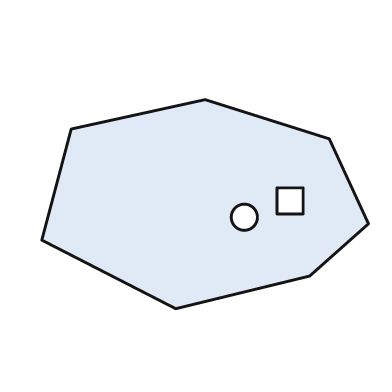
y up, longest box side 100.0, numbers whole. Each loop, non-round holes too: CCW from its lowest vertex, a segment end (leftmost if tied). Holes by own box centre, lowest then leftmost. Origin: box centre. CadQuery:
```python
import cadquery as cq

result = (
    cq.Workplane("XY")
    .moveTo(-9.0, -32.0)
    .lineTo(32.0, -22.0)
    .lineTo(50.0, -6.0)
    .lineTo(38.0, 20.0)
    .lineTo(0.0, 32.0)
    .lineTo(-41.0, 23.0)
    .lineTo(-50.0, -11.0)
    .close()
    .moveTo(12.0, -4.0)
    .circle(4.0)
    .moveTo(22.0, -3.0)
    .lineTo(30.0, -3.0)
    .lineTo(30.0, 5.0)
    .lineTo(22.0, 5.0)
    .close()
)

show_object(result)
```